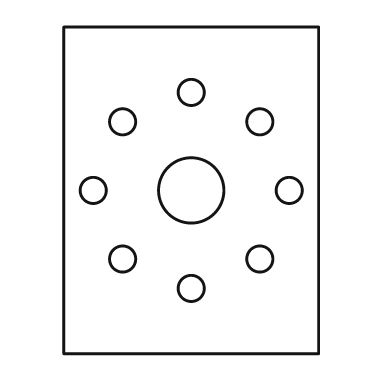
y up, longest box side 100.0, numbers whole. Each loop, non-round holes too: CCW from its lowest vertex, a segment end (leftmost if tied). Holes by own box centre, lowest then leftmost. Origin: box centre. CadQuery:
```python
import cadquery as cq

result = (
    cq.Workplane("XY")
    .moveTo(-39.0, -50.0)
    .lineTo(39.0, -50.0)
    .lineTo(39.0, 50.0)
    .lineTo(-39.0, 50.0)
    .close()
    .moveTo(0.0, -30.0)
    .circle(4.0)
    .moveTo(-21.0, -21.0)
    .circle(4.0)
    .moveTo(21.0, -21.0)
    .circle(4.0)
    .moveTo(-30.0, 0.0)
    .circle(4.0)
    .moveTo(0.0, 0.0)
    .circle(10.0)
    .moveTo(30.0, 0.0)
    .circle(4.0)
    .moveTo(-21.0, 21.0)
    .circle(4.0)
    .moveTo(21.0, 21.0)
    .circle(4.0)
    .moveTo(0.0, 30.0)
    .circle(4.0)
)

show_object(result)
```